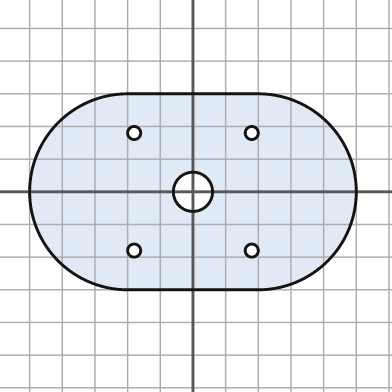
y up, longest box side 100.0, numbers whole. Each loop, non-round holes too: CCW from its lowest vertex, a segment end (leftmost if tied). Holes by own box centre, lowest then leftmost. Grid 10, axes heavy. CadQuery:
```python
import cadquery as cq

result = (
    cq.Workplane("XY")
    .moveTo(-20.0, -30.0)
    .lineTo(20.0, -30.0)
    .threePointArc((50.0, 0.0), (20.0, 30.0))
    .lineTo(-20.0, 30.0)
    .threePointArc((-50.0, 0.0), (-20.0, -30.0))
    .close()
    .moveTo(-18.0, -18.0)
    .circle(2.0)
    .moveTo(18.0, -18.0)
    .circle(2.0)
    .moveTo(0.0, 0.0)
    .circle(6.0)
    .moveTo(-18.0, 18.0)
    .circle(2.0)
    .moveTo(18.0, 18.0)
    .circle(2.0)
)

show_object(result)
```